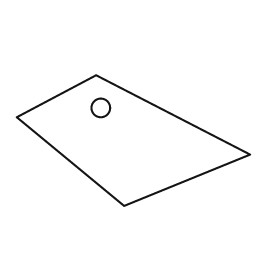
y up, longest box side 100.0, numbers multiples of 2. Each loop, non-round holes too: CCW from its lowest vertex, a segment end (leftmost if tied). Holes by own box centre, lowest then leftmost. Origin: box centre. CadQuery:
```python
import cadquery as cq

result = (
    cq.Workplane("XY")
    .moveTo(-4.0, -28.0)
    .lineTo(50.0, -6.0)
    .lineTo(-16.0, 28.0)
    .lineTo(-50.0, 10.0)
    .close()
    .moveTo(-14.0, 14.0)
    .circle(4.0)
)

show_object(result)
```